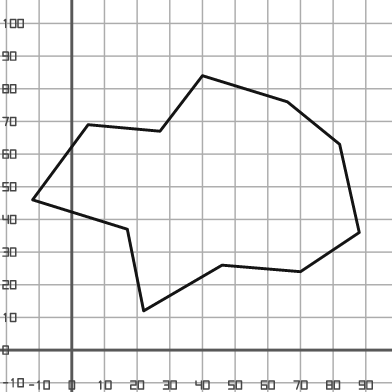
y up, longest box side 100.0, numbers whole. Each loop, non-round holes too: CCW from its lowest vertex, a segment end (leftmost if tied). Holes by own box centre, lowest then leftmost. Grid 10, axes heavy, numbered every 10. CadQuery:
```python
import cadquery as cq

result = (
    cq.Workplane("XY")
    .moveTo(22.0, 12.0)
    .lineTo(46.0, 26.0)
    .lineTo(70.0, 24.0)
    .lineTo(88.0, 36.0)
    .lineTo(82.0, 63.0)
    .lineTo(66.0, 76.0)
    .lineTo(40.0, 84.0)
    .lineTo(27.0, 67.0)
    .lineTo(5.0, 69.0)
    .lineTo(-12.0, 46.0)
    .lineTo(17.0, 37.0)
    .close()
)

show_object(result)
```